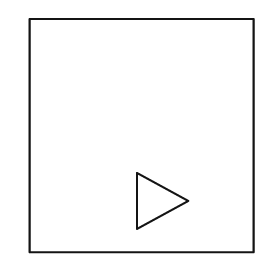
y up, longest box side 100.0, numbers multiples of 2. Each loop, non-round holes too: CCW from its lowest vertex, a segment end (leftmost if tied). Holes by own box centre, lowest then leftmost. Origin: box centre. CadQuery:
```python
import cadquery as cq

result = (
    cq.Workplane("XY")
    .moveTo(-48.0, -50.0)
    .lineTo(48.0, -50.0)
    .lineTo(48.0, 50.0)
    .lineTo(-48.0, 50.0)
    .close()
    .moveTo(-2.0, -40.0)
    .lineTo(20.0, -28.0)
    .lineTo(-2.0, -16.0)
    .close()
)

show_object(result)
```